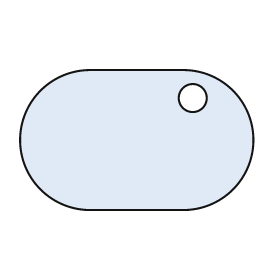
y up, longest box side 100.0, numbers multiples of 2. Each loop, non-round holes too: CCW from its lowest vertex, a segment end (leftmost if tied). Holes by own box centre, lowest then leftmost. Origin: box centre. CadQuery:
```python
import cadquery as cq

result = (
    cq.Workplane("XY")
    .moveTo(-20.0, -30.0)
    .lineTo(20.0, -30.0)
    .threePointArc((50.0, 0.0), (20.0, 30.0))
    .lineTo(-20.0, 30.0)
    .threePointArc((-50.0, 0.0), (-20.0, -30.0))
    .close()
    .moveTo(24.0, 18.0)
    .circle(6.0)
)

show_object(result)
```